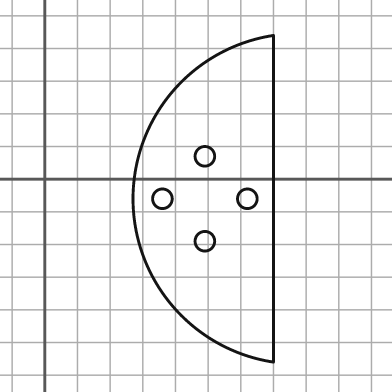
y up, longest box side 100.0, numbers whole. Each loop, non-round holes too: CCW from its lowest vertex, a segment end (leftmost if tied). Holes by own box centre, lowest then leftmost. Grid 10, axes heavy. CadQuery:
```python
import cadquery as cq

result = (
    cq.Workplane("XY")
    .moveTo(70.0, -56.0)
    .lineTo(70.0, 44.0)
    .threePointArc((27.0, -6.0), (70.0, -56.0))
    .close()
    .moveTo(49.0, -19.0)
    .circle(3.0)
    .moveTo(36.0, -6.0)
    .circle(3.0)
    .moveTo(62.0, -6.0)
    .circle(3.0)
    .moveTo(49.0, 7.0)
    .circle(3.0)
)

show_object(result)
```